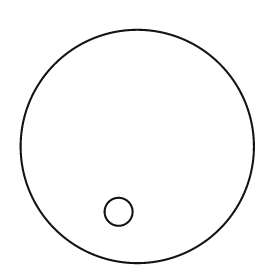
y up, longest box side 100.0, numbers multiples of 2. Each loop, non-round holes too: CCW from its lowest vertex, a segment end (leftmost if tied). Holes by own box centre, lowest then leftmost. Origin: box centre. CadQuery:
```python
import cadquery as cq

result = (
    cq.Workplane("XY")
    .moveTo(0.0, 0.0)
    .circle(50.0)
    .moveTo(-8.0, -28.0)
    .circle(6.0)
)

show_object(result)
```